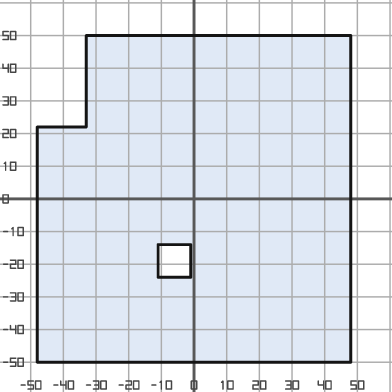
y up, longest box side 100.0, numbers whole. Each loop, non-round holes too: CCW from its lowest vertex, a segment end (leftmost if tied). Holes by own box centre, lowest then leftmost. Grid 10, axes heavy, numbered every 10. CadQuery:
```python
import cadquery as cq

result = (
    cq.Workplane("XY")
    .moveTo(-48.0, -50.0)
    .lineTo(48.0, -50.0)
    .lineTo(48.0, 50.0)
    .lineTo(-33.0, 50.0)
    .lineTo(-33.0, 22.0)
    .lineTo(-48.0, 22.0)
    .close()
    .moveTo(-11.0, -24.0)
    .lineTo(-1.0, -24.0)
    .lineTo(-1.0, -14.0)
    .lineTo(-11.0, -14.0)
    .close()
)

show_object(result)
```